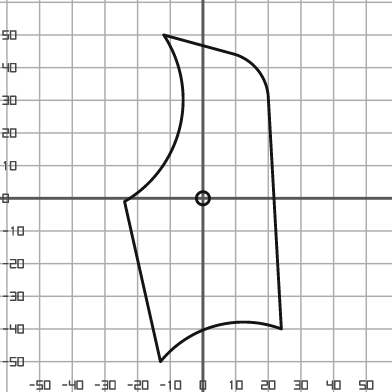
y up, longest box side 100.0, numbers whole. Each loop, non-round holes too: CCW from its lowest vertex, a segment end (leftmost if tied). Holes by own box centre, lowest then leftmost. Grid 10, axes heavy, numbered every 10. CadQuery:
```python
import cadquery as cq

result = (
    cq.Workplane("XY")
    .moveTo(-13.0, -50.0)
    .threePointArc((4.0, -39.0), (24.0, -40.0))
    .lineTo(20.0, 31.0)
    .threePointArc((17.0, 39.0), (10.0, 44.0))
    .lineTo(-12.0, 50.0)
    .threePointArc((-7.0, 22.0), (-24.0, -1.0))
    .close()
    .moveTo(0.0, 0.0)
    .circle(2.0)
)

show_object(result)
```